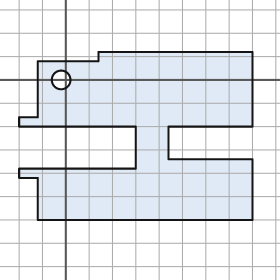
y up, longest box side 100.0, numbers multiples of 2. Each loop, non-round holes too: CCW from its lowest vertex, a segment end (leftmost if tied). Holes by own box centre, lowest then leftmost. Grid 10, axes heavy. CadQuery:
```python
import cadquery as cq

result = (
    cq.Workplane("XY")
    .moveTo(-12.0, -60.0)
    .lineTo(80.0, -60.0)
    .lineTo(80.0, -34.0)
    .lineTo(44.0, -34.0)
    .lineTo(44.0, -20.0)
    .lineTo(80.0, -20.0)
    .lineTo(80.0, 12.0)
    .lineTo(14.0, 12.0)
    .lineTo(14.0, 8.0)
    .lineTo(-12.0, 8.0)
    .lineTo(-12.0, -16.0)
    .lineTo(-20.0, -16.0)
    .lineTo(-20.0, -20.0)
    .lineTo(30.0, -20.0)
    .lineTo(30.0, -38.0)
    .lineTo(-20.0, -38.0)
    .lineTo(-20.0, -42.0)
    .lineTo(-12.0, -42.0)
    .close()
    .moveTo(-2.0, 0.0)
    .circle(4.0)
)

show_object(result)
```